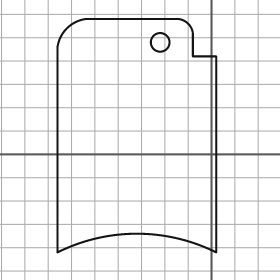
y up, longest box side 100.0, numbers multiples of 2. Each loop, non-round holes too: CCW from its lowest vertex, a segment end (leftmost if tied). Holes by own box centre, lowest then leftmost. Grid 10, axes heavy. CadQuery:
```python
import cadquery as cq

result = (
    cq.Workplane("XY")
    .moveTo(-66.0, -42.0)
    .threePointArc((-32.0, -34.0), (2.0, -42.0))
    .lineTo(2.0, 42.0)
    .lineTo(-8.0, 42.0)
    .lineTo(-8.0, 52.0)
    .threePointArc((-10.0, 56.0), (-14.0, 58.0))
    .lineTo(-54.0, 58.0)
    .threePointArc((-62.0, 54.0), (-66.0, 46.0))
    .close()
    .moveTo(-22.0, 48.0)
    .circle(4.0)
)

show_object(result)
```